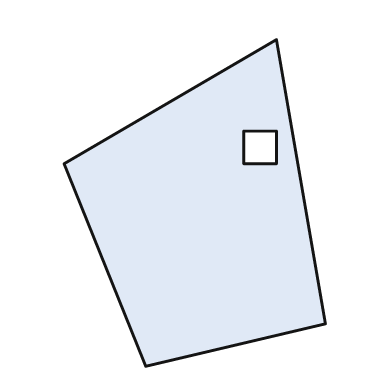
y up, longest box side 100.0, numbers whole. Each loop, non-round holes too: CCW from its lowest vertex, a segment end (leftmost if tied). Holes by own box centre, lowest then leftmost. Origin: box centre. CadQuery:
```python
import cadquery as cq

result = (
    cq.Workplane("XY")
    .moveTo(-15.0, -50.0)
    .lineTo(40.0, -37.0)
    .lineTo(25.0, 50.0)
    .lineTo(-40.0, 12.0)
    .close()
    .moveTo(15.0, 12.0)
    .lineTo(25.0, 12.0)
    .lineTo(25.0, 22.0)
    .lineTo(15.0, 22.0)
    .close()
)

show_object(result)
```